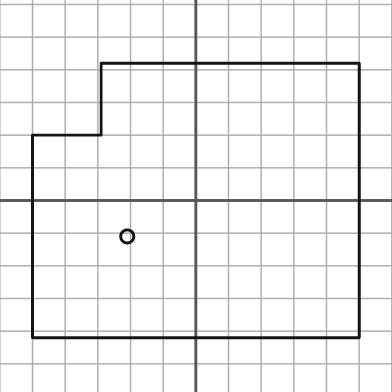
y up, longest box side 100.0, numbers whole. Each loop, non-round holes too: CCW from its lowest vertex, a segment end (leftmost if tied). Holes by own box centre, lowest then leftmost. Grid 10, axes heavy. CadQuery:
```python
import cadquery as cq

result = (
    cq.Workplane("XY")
    .moveTo(-50.0, -42.0)
    .lineTo(50.0, -42.0)
    .lineTo(50.0, 42.0)
    .lineTo(-29.0, 42.0)
    .lineTo(-29.0, 20.0)
    .lineTo(-50.0, 20.0)
    .close()
    .moveTo(-21.0, -11.0)
    .circle(2.0)
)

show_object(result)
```